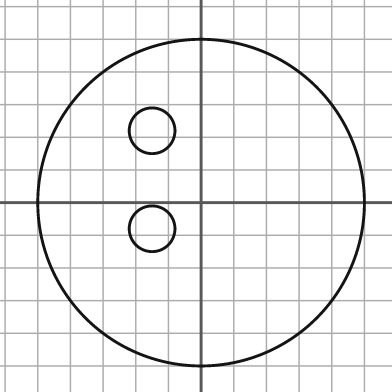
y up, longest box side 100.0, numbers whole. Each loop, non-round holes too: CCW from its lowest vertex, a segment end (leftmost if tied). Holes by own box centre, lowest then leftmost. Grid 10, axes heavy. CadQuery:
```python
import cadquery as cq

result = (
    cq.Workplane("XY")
    .moveTo(0.0, 0.0)
    .circle(50.0)
    .moveTo(-15.0, -8.0)
    .circle(7.0)
    .moveTo(-15.0, 22.0)
    .circle(7.0)
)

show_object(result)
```